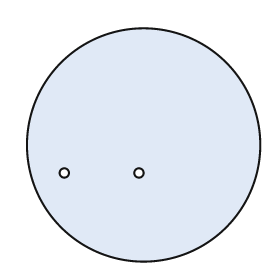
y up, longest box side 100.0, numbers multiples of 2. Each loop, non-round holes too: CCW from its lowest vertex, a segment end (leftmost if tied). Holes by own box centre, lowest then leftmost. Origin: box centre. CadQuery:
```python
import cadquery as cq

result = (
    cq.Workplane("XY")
    .moveTo(0.0, 0.0)
    .circle(50.0)
    .moveTo(-34.0, -12.0)
    .circle(2.0)
    .moveTo(-2.0, -12.0)
    .circle(2.0)
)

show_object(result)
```